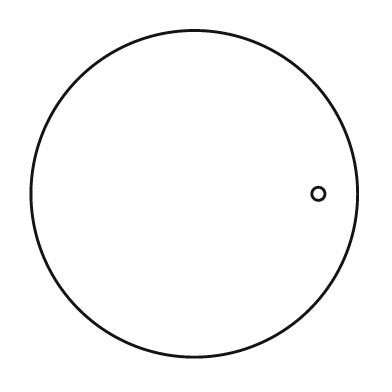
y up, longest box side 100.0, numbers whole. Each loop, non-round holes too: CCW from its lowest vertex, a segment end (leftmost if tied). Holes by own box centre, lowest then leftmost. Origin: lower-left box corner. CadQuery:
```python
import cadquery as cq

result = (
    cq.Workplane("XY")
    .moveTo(50.0, 50.0)
    .circle(50.0)
    .moveTo(88.0, 50.0)
    .circle(2.0)
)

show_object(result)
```